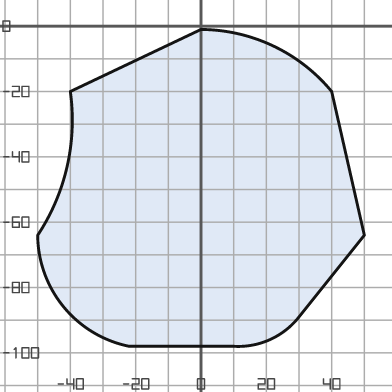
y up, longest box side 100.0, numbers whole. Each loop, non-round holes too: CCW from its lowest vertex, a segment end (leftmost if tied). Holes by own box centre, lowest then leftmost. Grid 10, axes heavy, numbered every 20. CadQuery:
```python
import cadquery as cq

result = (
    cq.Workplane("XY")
    .moveTo(-22.0, -98.0)
    .lineTo(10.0, -98.0)
    .threePointArc((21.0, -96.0), (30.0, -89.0))
    .lineTo(50.0, -64.0)
    .lineTo(40.0, -20.0)
    .threePointArc((22.0, -6.0), (0.0, -1.0))
    .lineTo(-40.0, -20.0)
    .threePointArc((-41.0, -43.0), (-50.0, -64.0))
    .threePointArc((-42.0, -86.0), (-22.0, -98.0))
    .close()
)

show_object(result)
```